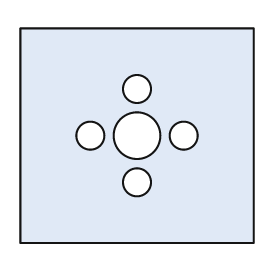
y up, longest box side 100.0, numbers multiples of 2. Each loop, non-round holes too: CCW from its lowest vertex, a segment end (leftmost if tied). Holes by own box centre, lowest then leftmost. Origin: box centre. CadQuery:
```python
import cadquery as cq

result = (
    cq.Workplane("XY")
    .moveTo(-50.0, -46.0)
    .lineTo(50.0, -46.0)
    .lineTo(50.0, 46.0)
    .lineTo(-50.0, 46.0)
    .close()
    .moveTo(0.0, -20.0)
    .circle(6.0)
    .moveTo(-20.0, 0.0)
    .circle(6.0)
    .moveTo(0.0, 0.0)
    .circle(10.0)
    .moveTo(20.0, 0.0)
    .circle(6.0)
    .moveTo(0.0, 20.0)
    .circle(6.0)
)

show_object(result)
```